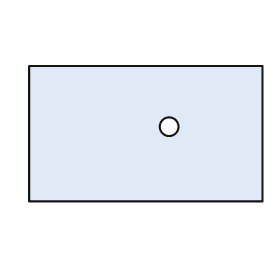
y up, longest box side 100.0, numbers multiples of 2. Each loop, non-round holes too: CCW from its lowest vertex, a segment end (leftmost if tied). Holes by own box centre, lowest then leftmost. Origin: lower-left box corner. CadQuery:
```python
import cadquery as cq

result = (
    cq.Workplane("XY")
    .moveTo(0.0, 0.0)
    .lineTo(100.0, 0.0)
    .lineTo(100.0, 58.0)
    .lineTo(0.0, 58.0)
    .close()
    .moveTo(60.0, 32.0)
    .circle(4.0)
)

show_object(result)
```